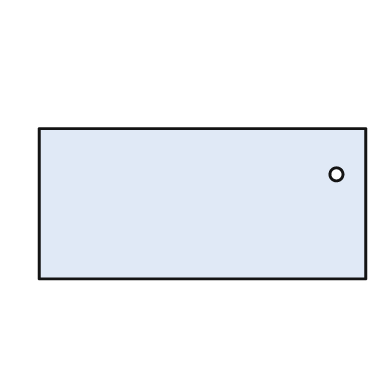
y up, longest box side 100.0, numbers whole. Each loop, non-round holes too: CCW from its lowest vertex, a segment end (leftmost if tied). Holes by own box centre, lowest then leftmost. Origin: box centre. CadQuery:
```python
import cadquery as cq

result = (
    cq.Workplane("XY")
    .moveTo(-50.0, -23.0)
    .lineTo(50.0, -23.0)
    .lineTo(50.0, 23.0)
    .lineTo(-50.0, 23.0)
    .close()
    .moveTo(41.0, 9.0)
    .circle(2.0)
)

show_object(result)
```